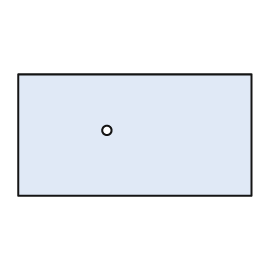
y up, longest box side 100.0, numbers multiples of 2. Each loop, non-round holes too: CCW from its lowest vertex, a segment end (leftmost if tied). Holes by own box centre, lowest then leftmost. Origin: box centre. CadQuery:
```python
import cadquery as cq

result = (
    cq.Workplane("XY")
    .moveTo(-50.0, -26.0)
    .lineTo(50.0, -26.0)
    .lineTo(50.0, 26.0)
    .lineTo(-50.0, 26.0)
    .close()
    .moveTo(-12.0, 2.0)
    .circle(2.0)
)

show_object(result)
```